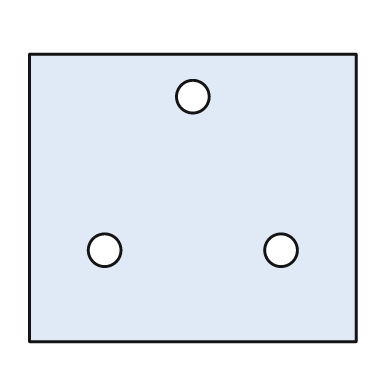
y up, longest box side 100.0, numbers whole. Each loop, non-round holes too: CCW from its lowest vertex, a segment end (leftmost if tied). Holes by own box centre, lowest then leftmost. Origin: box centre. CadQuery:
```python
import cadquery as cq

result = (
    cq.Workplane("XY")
    .moveTo(-50.0, -44.0)
    .lineTo(50.0, -44.0)
    .lineTo(50.0, 44.0)
    .lineTo(-50.0, 44.0)
    .close()
    .moveTo(-27.0, -16.0)
    .circle(5.0)
    .moveTo(27.0, -16.0)
    .circle(5.0)
    .moveTo(0.0, 31.0)
    .circle(5.0)
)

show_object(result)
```